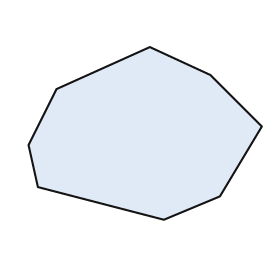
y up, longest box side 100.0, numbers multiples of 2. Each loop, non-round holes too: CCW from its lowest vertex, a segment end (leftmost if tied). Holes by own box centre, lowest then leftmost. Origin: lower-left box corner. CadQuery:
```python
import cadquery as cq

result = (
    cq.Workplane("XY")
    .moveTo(58.0, 0.0)
    .lineTo(82.0, 10.0)
    .lineTo(100.0, 40.0)
    .lineTo(78.0, 62.0)
    .lineTo(52.0, 74.0)
    .lineTo(12.0, 56.0)
    .lineTo(0.0, 32.0)
    .lineTo(4.0, 14.0)
    .close()
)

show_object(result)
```